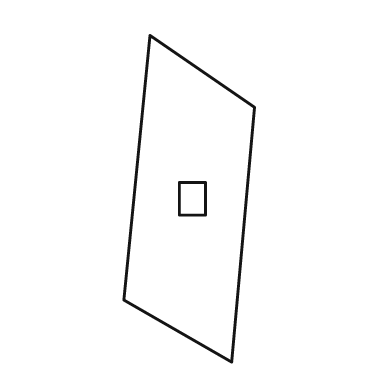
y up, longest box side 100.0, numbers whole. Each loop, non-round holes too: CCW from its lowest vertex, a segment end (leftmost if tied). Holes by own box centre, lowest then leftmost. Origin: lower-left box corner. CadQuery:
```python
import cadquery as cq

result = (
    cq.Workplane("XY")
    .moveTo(33.0, 0.0)
    .lineTo(40.0, 78.0)
    .lineTo(8.0, 100.0)
    .lineTo(0.0, 19.0)
    .close()
    .moveTo(17.0, 45.0)
    .lineTo(25.0, 45.0)
    .lineTo(25.0, 55.0)
    .lineTo(17.0, 55.0)
    .close()
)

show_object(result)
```